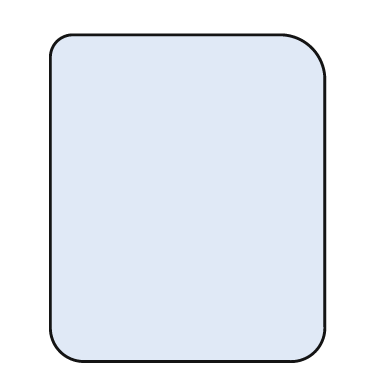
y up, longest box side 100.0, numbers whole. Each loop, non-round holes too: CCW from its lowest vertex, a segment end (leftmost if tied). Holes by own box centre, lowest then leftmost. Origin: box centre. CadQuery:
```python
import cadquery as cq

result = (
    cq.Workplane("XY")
    .moveTo(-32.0, -50.0)
    .lineTo(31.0, -50.0)
    .threePointArc((39.0, -47.0), (42.0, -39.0))
    .lineTo(42.0, 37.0)
    .threePointArc((38.0, 46.0), (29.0, 50.0))
    .lineTo(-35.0, 50.0)
    .threePointArc((-40.0, 48.0), (-42.0, 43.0))
    .lineTo(-42.0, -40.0)
    .threePointArc((-39.0, -47.0), (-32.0, -50.0))
    .close()
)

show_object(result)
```